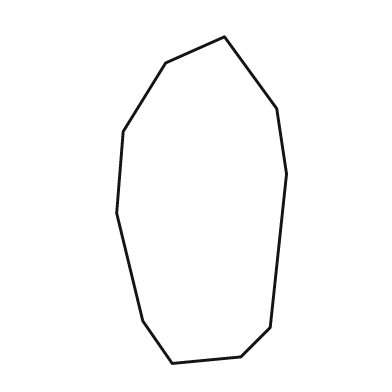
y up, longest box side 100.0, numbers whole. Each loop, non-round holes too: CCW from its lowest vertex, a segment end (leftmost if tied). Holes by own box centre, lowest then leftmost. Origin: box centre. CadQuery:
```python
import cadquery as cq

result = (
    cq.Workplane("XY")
    .moveTo(-9.0, -50.0)
    .lineTo(12.0, -48.0)
    .lineTo(21.0, -39.0)
    .lineTo(26.0, 8.0)
    .lineTo(23.0, 28.0)
    .lineTo(7.0, 50.0)
    .lineTo(-11.0, 42.0)
    .lineTo(-24.0, 21.0)
    .lineTo(-26.0, -4.0)
    .lineTo(-18.0, -37.0)
    .close()
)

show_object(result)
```